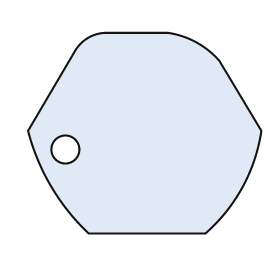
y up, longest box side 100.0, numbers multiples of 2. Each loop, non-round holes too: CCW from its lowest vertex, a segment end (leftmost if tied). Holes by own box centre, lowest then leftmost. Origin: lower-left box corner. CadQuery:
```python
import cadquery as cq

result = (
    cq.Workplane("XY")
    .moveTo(26.0, 0.0)
    .lineTo(76.0, 0.0)
    .threePointArc((92.0, 20.0), (100.0, 44.0))
    .lineTo(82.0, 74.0)
    .threePointArc((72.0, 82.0), (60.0, 86.0))
    .lineTo(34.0, 86.0)
    .threePointArc((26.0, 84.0), (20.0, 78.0))
    .lineTo(0.0, 44.0)
    .threePointArc((10.0, 20.0), (26.0, 0.0))
    .close()
    .moveTo(16.0, 36.0)
    .circle(6.0)
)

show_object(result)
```